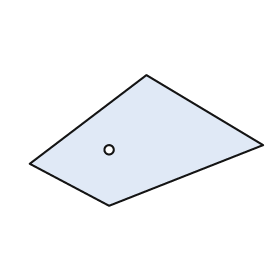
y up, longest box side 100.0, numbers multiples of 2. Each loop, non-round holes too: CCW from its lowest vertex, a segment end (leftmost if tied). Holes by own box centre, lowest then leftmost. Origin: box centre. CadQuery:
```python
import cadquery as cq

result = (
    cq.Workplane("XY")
    .moveTo(-16.0, -28.0)
    .lineTo(50.0, -2.0)
    .lineTo(0.0, 28.0)
    .lineTo(-50.0, -10.0)
    .close()
    .moveTo(-16.0, -4.0)
    .circle(2.0)
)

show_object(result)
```